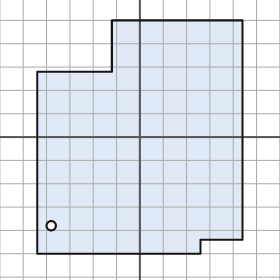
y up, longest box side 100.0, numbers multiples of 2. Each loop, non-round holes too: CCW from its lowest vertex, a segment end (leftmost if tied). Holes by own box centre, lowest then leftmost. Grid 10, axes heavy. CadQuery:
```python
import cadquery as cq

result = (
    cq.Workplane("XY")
    .moveTo(-44.0, -50.0)
    .lineTo(26.0, -50.0)
    .lineTo(26.0, -44.0)
    .lineTo(44.0, -44.0)
    .lineTo(44.0, 50.0)
    .lineTo(-12.0, 50.0)
    .lineTo(-12.0, 28.0)
    .lineTo(-44.0, 28.0)
    .close()
    .moveTo(-38.0, -38.0)
    .circle(2.0)
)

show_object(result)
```